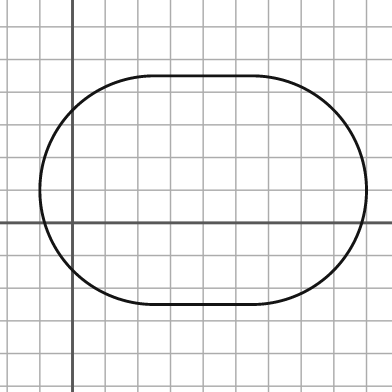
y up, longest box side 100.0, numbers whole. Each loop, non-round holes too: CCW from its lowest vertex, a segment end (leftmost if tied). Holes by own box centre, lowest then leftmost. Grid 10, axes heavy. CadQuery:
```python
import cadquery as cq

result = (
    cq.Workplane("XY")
    .moveTo(25.0, -25.0)
    .lineTo(55.0, -25.0)
    .threePointArc((90.0, 10.0), (55.0, 45.0))
    .lineTo(25.0, 45.0)
    .threePointArc((-10.0, 10.0), (25.0, -25.0))
    .close()
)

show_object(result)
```